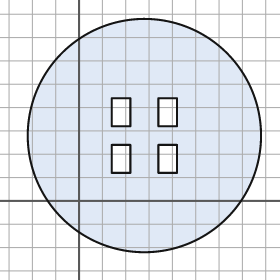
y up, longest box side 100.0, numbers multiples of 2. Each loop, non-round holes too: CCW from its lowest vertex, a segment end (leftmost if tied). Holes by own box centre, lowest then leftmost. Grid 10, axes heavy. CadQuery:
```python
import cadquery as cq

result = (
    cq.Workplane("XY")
    .moveTo(28.0, 28.0)
    .circle(50.0)
    .moveTo(14.0, 12.0)
    .lineTo(22.0, 12.0)
    .lineTo(22.0, 24.0)
    .lineTo(14.0, 24.0)
    .close()
    .moveTo(34.0, 12.0)
    .lineTo(42.0, 12.0)
    .lineTo(42.0, 24.0)
    .lineTo(34.0, 24.0)
    .close()
    .moveTo(14.0, 32.0)
    .lineTo(22.0, 32.0)
    .lineTo(22.0, 44.0)
    .lineTo(14.0, 44.0)
    .close()
    .moveTo(34.0, 32.0)
    .lineTo(42.0, 32.0)
    .lineTo(42.0, 44.0)
    .lineTo(34.0, 44.0)
    .close()
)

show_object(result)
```